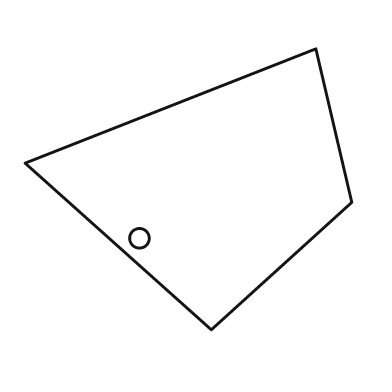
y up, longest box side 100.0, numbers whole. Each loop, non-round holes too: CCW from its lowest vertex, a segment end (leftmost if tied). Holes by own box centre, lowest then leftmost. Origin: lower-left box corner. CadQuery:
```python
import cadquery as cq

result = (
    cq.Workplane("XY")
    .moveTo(57.0, 0.0)
    .lineTo(100.0, 39.0)
    .lineTo(89.0, 86.0)
    .lineTo(0.0, 51.0)
    .close()
    .moveTo(35.0, 28.0)
    .circle(3.0)
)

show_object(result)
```